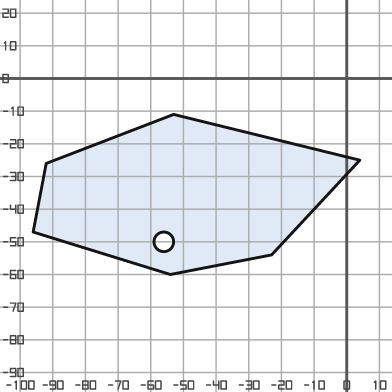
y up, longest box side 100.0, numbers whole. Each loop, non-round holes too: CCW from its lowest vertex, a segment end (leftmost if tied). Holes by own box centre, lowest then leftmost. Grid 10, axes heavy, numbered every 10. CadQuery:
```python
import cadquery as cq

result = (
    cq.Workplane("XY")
    .moveTo(-54.0, -60.0)
    .lineTo(-23.0, -54.0)
    .lineTo(4.0, -25.0)
    .lineTo(-53.0, -11.0)
    .lineTo(-92.0, -26.0)
    .lineTo(-96.0, -47.0)
    .close()
    .moveTo(-56.0, -50.0)
    .circle(3.0)
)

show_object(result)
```